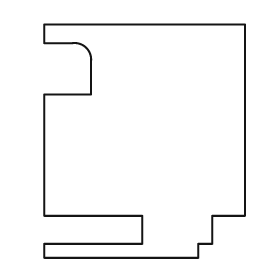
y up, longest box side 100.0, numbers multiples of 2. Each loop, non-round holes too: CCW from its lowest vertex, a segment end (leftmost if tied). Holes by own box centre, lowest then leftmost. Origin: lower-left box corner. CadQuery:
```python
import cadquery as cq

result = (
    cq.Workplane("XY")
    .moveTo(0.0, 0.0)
    .lineTo(66.0, 0.0)
    .lineTo(66.0, 6.0)
    .lineTo(72.0, 6.0)
    .lineTo(72.0, 18.0)
    .lineTo(86.0, 18.0)
    .lineTo(86.0, 100.0)
    .lineTo(0.0, 100.0)
    .lineTo(0.0, 92.0)
    .lineTo(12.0, 92.0)
    .threePointArc((18.0, 90.0), (20.0, 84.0))
    .lineTo(20.0, 70.0)
    .lineTo(0.0, 70.0)
    .lineTo(0.0, 18.0)
    .lineTo(42.0, 18.0)
    .lineTo(42.0, 6.0)
    .lineTo(0.0, 6.0)
    .close()
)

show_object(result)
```